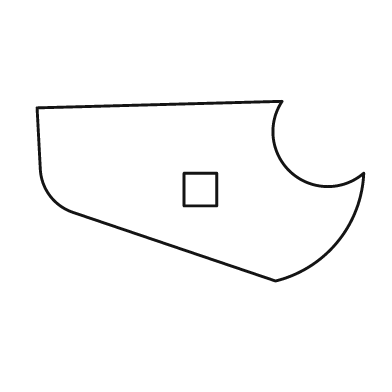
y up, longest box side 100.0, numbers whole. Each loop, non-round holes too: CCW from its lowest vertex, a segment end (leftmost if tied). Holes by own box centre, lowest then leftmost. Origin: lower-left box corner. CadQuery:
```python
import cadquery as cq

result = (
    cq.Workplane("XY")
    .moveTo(73.0, 0.0)
    .threePointArc((92.0, 12.0), (100.0, 33.0))
    .threePointArc((78.0, 33.0), (75.0, 55.0))
    .lineTo(0.0, 53.0)
    .lineTo(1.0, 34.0)
    .threePointArc((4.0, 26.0), (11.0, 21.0))
    .close()
    .moveTo(45.0, 23.0)
    .lineTo(55.0, 23.0)
    .lineTo(55.0, 33.0)
    .lineTo(45.0, 33.0)
    .close()
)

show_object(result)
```